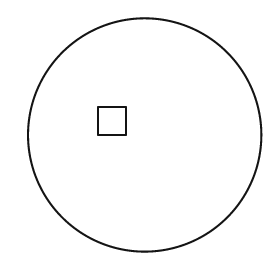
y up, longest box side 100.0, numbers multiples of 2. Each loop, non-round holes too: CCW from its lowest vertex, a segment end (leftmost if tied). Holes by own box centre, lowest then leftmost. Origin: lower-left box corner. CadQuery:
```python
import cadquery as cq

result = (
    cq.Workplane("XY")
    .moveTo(50.0, 50.0)
    .circle(50.0)
    .moveTo(30.0, 50.0)
    .lineTo(42.0, 50.0)
    .lineTo(42.0, 62.0)
    .lineTo(30.0, 62.0)
    .close()
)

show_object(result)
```